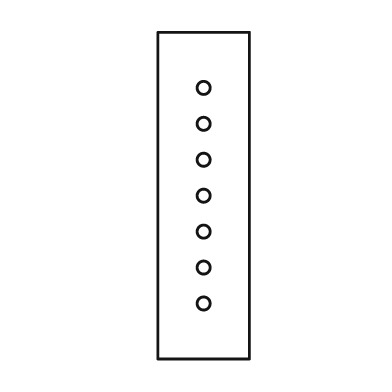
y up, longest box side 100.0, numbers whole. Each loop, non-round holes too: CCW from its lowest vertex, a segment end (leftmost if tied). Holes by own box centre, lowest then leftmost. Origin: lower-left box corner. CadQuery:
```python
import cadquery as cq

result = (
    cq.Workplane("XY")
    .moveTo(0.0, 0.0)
    .lineTo(28.0, 0.0)
    .lineTo(28.0, 100.0)
    .lineTo(0.0, 100.0)
    .close()
    .moveTo(14.0, 17.0)
    .circle(2.0)
    .moveTo(14.0, 28.0)
    .circle(2.0)
    .moveTo(14.0, 39.0)
    .circle(2.0)
    .moveTo(14.0, 50.0)
    .circle(2.0)
    .moveTo(14.0, 61.0)
    .circle(2.0)
    .moveTo(14.0, 72.0)
    .circle(2.0)
    .moveTo(14.0, 83.0)
    .circle(2.0)
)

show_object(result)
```